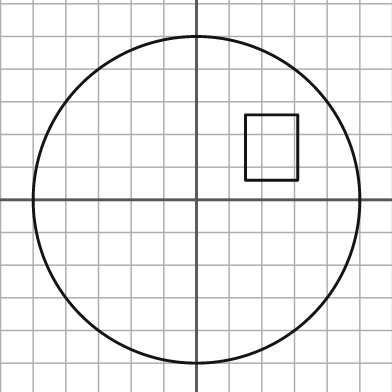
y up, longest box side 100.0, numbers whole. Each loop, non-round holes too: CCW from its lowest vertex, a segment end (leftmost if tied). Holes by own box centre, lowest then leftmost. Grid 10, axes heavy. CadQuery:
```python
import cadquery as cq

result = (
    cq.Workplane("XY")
    .moveTo(0.0, 0.0)
    .circle(50.0)
    .moveTo(15.0, 6.0)
    .lineTo(31.0, 6.0)
    .lineTo(31.0, 26.0)
    .lineTo(15.0, 26.0)
    .close()
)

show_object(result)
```